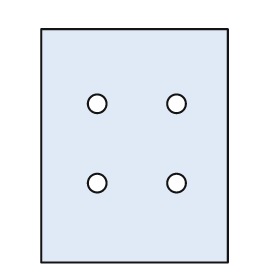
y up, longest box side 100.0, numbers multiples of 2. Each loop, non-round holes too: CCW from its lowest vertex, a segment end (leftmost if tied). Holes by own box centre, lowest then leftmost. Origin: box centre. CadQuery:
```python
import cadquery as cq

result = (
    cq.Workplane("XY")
    .moveTo(-40.0, -50.0)
    .lineTo(40.0, -50.0)
    .lineTo(40.0, 50.0)
    .lineTo(-40.0, 50.0)
    .close()
    .moveTo(-16.0, -16.0)
    .circle(4.0)
    .moveTo(18.0, -16.0)
    .circle(4.0)
    .moveTo(-16.0, 18.0)
    .circle(4.0)
    .moveTo(18.0, 18.0)
    .circle(4.0)
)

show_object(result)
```